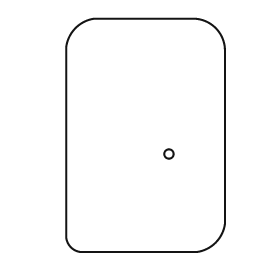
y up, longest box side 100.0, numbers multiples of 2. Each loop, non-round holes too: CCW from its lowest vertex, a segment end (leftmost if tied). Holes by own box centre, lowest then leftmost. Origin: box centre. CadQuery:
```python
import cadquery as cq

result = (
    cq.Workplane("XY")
    .moveTo(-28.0, -50.0)
    .lineTo(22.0, -50.0)
    .threePointArc((30.0, -46.0), (34.0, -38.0))
    .lineTo(34.0, 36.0)
    .threePointArc((30.0, 46.0), (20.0, 50.0))
    .lineTo(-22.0, 50.0)
    .threePointArc((-30.0, 46.0), (-34.0, 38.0))
    .lineTo(-34.0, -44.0)
    .threePointArc((-32.0, -48.0), (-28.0, -50.0))
    .close()
    .moveTo(10.0, -8.0)
    .circle(2.0)
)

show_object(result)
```